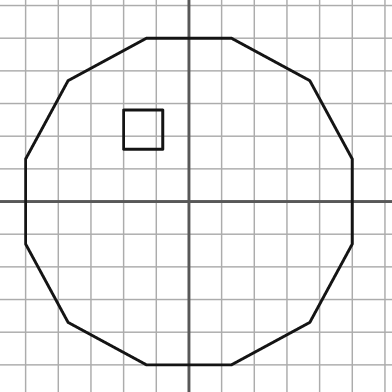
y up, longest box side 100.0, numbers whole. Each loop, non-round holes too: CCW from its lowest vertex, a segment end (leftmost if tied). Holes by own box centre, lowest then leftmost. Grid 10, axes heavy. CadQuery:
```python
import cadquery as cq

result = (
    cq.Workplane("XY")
    .moveTo(-13.0, -50.0)
    .lineTo(13.0, -50.0)
    .lineTo(37.0, -37.0)
    .lineTo(50.0, -13.0)
    .lineTo(50.0, 13.0)
    .lineTo(37.0, 37.0)
    .lineTo(13.0, 50.0)
    .lineTo(-13.0, 50.0)
    .lineTo(-37.0, 37.0)
    .lineTo(-50.0, 13.0)
    .lineTo(-50.0, -13.0)
    .lineTo(-37.0, -37.0)
    .close()
    .moveTo(-20.0, 16.0)
    .lineTo(-8.0, 16.0)
    .lineTo(-8.0, 28.0)
    .lineTo(-20.0, 28.0)
    .close()
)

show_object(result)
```